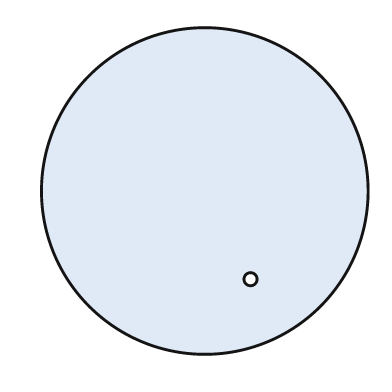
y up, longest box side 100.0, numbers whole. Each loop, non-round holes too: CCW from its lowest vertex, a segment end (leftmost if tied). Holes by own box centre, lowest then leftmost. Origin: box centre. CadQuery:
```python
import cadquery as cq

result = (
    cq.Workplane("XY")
    .moveTo(0.0, 0.0)
    .circle(50.0)
    .moveTo(14.0, -27.0)
    .circle(2.0)
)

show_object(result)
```